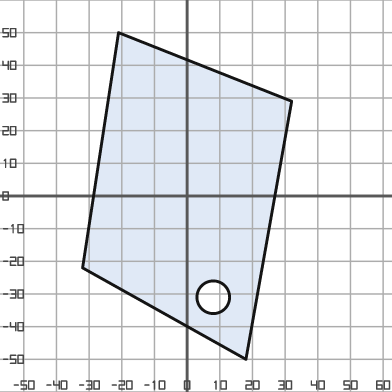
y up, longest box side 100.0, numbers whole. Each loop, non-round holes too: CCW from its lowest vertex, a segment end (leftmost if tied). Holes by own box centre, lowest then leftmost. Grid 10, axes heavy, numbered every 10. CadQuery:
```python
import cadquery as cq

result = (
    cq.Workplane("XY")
    .moveTo(18.0, -50.0)
    .lineTo(32.0, 29.0)
    .lineTo(-21.0, 50.0)
    .lineTo(-32.0, -22.0)
    .close()
    .moveTo(8.0, -31.0)
    .circle(5.0)
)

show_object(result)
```